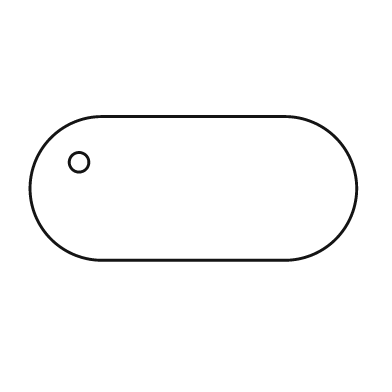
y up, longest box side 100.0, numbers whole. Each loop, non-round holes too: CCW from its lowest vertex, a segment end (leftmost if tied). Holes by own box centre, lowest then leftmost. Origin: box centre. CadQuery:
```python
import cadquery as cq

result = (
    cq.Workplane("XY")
    .moveTo(-28.0, -22.0)
    .lineTo(28.0, -22.0)
    .threePointArc((50.0, 0.0), (28.0, 22.0))
    .lineTo(-28.0, 22.0)
    .threePointArc((-50.0, 0.0), (-28.0, -22.0))
    .close()
    .moveTo(-35.0, 8.0)
    .circle(3.0)
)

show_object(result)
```